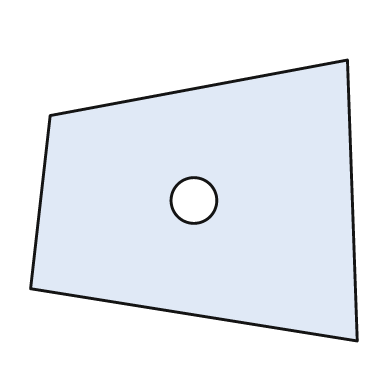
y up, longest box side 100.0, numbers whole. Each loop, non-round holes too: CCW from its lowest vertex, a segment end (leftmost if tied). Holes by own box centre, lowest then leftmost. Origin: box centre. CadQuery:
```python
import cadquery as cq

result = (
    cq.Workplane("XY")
    .moveTo(50.0, -43.0)
    .lineTo(47.0, 43.0)
    .lineTo(-44.0, 26.0)
    .lineTo(-50.0, -27.0)
    .close()
    .moveTo(0.0, 0.0)
    .circle(7.0)
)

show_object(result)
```